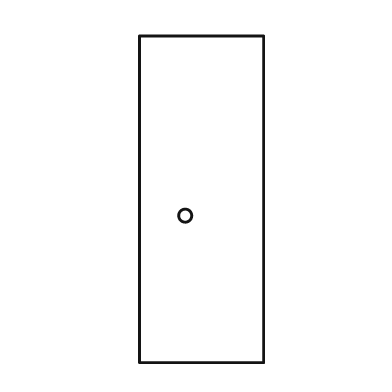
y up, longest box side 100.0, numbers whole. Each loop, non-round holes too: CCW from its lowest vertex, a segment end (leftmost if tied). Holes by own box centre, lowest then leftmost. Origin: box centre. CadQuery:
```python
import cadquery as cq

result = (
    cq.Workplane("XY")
    .moveTo(-19.0, -50.0)
    .lineTo(19.0, -50.0)
    .lineTo(19.0, 50.0)
    .lineTo(-19.0, 50.0)
    .close()
    .moveTo(-5.0, -5.0)
    .circle(2.0)
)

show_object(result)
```